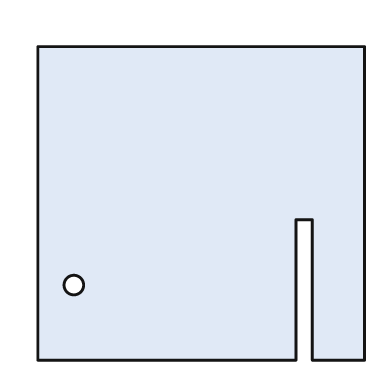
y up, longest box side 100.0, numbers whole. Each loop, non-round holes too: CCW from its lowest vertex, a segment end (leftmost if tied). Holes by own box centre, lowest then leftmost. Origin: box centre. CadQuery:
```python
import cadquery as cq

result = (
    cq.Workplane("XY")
    .moveTo(-50.0, -48.0)
    .lineTo(29.0, -48.0)
    .lineTo(29.0, -5.0)
    .lineTo(34.0, -5.0)
    .lineTo(34.0, -48.0)
    .lineTo(50.0, -48.0)
    .lineTo(50.0, 48.0)
    .lineTo(-50.0, 48.0)
    .close()
    .moveTo(-39.0, -25.0)
    .circle(3.0)
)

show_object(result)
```